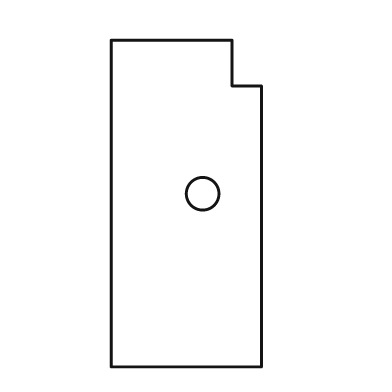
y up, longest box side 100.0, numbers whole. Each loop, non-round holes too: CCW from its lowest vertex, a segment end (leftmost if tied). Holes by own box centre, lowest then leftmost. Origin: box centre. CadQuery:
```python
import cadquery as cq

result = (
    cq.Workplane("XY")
    .moveTo(-23.0, -50.0)
    .lineTo(23.0, -50.0)
    .lineTo(23.0, 36.0)
    .lineTo(14.0, 36.0)
    .lineTo(14.0, 50.0)
    .lineTo(-23.0, 50.0)
    .close()
    .moveTo(5.0, 3.0)
    .circle(5.0)
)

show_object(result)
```